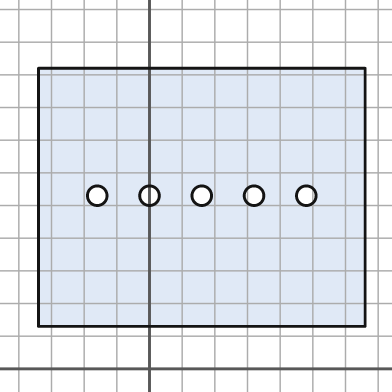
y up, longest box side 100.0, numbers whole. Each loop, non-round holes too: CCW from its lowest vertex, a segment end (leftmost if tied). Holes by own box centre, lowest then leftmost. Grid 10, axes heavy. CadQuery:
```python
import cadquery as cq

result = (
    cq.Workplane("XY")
    .moveTo(-34.0, 13.0)
    .lineTo(66.0, 13.0)
    .lineTo(66.0, 92.0)
    .lineTo(-34.0, 92.0)
    .close()
    .moveTo(-16.0, 53.0)
    .circle(3.0)
    .moveTo(0.0, 53.0)
    .circle(3.0)
    .moveTo(16.0, 53.0)
    .circle(3.0)
    .moveTo(32.0, 53.0)
    .circle(3.0)
    .moveTo(48.0, 53.0)
    .circle(3.0)
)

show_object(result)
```